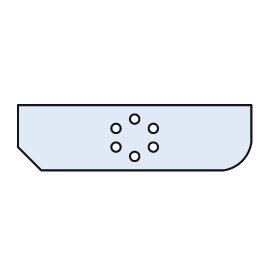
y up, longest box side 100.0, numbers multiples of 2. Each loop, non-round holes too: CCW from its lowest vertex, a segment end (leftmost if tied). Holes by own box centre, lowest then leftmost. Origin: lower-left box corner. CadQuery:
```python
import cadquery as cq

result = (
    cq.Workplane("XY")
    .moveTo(10.0, 0.0)
    .lineTo(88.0, 0.0)
    .threePointArc((96.0, 4.0), (100.0, 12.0))
    .lineTo(100.0, 28.0)
    .lineTo(0.0, 28.0)
    .lineTo(0.0, 10.0)
    .close()
    .moveTo(50.0, 6.0)
    .circle(2.0)
    .moveTo(42.0, 10.0)
    .circle(2.0)
    .moveTo(58.0, 10.0)
    .circle(2.0)
    .moveTo(42.0, 18.0)
    .circle(2.0)
    .moveTo(58.0, 18.0)
    .circle(2.0)
    .moveTo(50.0, 22.0)
    .circle(2.0)
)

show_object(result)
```